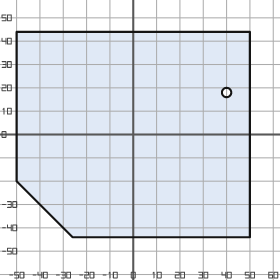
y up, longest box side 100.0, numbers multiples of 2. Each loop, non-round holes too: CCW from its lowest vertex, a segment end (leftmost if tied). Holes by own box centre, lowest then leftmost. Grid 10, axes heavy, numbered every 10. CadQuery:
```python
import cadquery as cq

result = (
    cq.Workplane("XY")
    .moveTo(-26.0, -44.0)
    .lineTo(50.0, -44.0)
    .lineTo(50.0, 44.0)
    .lineTo(-50.0, 44.0)
    .lineTo(-50.0, -20.0)
    .close()
    .moveTo(40.0, 18.0)
    .circle(2.0)
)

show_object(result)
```